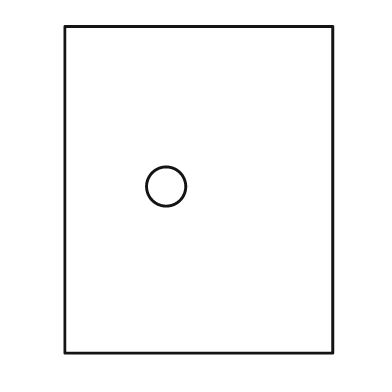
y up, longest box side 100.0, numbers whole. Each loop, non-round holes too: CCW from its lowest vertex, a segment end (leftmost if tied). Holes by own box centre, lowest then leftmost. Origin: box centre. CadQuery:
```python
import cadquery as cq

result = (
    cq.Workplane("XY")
    .moveTo(-41.0, -50.0)
    .lineTo(41.0, -50.0)
    .lineTo(41.0, 50.0)
    .lineTo(-41.0, 50.0)
    .close()
    .moveTo(-10.0, 1.0)
    .circle(6.0)
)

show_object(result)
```